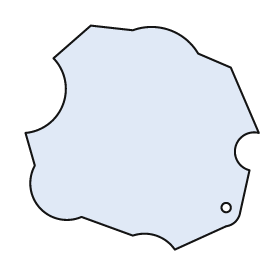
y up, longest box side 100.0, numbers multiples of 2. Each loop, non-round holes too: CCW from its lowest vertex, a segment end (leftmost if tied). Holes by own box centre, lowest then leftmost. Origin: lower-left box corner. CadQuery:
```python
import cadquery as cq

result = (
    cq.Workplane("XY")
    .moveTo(64.0, 0.0)
    .lineTo(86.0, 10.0)
    .threePointArc((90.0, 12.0), (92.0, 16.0))
    .lineTo(96.0, 34.0)
    .threePointArc((90.0, 44.0), (100.0, 50.0))
    .lineTo(88.0, 78.0)
    .lineTo(74.0, 84.0)
    .threePointArc((62.0, 94.0), (46.0, 94.0))
    .lineTo(28.0, 96.0)
    .lineTo(12.0, 82.0)
    .threePointArc((16.0, 62.0), (0.0, 50.0))
    .lineTo(4.0, 36.0)
    .threePointArc((6.0, 18.0), (24.0, 14.0))
    .lineTo(46.0, 6.0)
    .threePointArc((56.0, 6.0), (64.0, 0.0))
    .close()
    .moveTo(86.0, 18.0)
    .circle(2.0)
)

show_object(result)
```